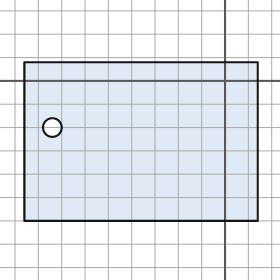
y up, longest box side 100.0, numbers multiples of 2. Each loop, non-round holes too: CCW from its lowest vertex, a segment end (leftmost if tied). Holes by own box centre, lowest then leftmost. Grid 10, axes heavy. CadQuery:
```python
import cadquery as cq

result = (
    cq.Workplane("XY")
    .moveTo(-86.0, -60.0)
    .lineTo(14.0, -60.0)
    .lineTo(14.0, 8.0)
    .lineTo(-86.0, 8.0)
    .close()
    .moveTo(-74.0, -20.0)
    .circle(4.0)
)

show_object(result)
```